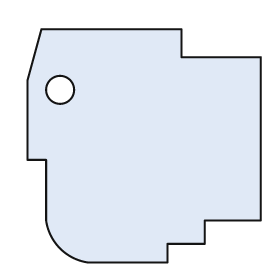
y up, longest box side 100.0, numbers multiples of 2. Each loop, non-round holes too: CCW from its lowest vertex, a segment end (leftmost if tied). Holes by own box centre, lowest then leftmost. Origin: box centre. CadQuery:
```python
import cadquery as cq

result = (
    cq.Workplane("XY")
    .moveTo(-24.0, -50.0)
    .lineTo(10.0, -50.0)
    .lineTo(10.0, -42.0)
    .lineTo(26.0, -42.0)
    .lineTo(26.0, -32.0)
    .lineTo(50.0, -32.0)
    .lineTo(50.0, 38.0)
    .lineTo(16.0, 38.0)
    .lineTo(16.0, 50.0)
    .lineTo(-44.0, 50.0)
    .lineTo(-50.0, 28.0)
    .lineTo(-50.0, -6.0)
    .lineTo(-42.0, -6.0)
    .lineTo(-42.0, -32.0)
    .threePointArc((-36.0, -44.0), (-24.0, -50.0))
    .close()
    .moveTo(-36.0, 24.0)
    .circle(6.0)
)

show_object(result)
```